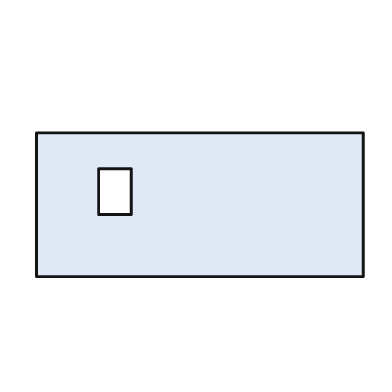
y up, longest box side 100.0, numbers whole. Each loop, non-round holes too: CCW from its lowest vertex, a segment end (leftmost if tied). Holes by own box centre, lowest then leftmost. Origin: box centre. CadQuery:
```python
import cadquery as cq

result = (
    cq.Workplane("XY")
    .moveTo(-50.0, -22.0)
    .lineTo(50.0, -22.0)
    .lineTo(50.0, 22.0)
    .lineTo(-50.0, 22.0)
    .close()
    .moveTo(-31.0, -3.0)
    .lineTo(-21.0, -3.0)
    .lineTo(-21.0, 11.0)
    .lineTo(-31.0, 11.0)
    .close()
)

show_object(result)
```